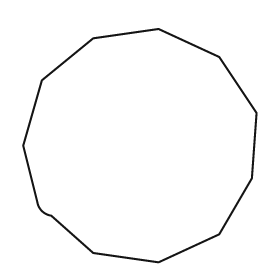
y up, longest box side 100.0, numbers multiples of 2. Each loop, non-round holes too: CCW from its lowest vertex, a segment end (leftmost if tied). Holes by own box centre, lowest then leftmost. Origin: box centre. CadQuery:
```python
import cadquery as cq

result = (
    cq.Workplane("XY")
    .moveTo(8.0, -50.0)
    .lineTo(34.0, -38.0)
    .lineTo(48.0, -14.0)
    .lineTo(50.0, 14.0)
    .lineTo(34.0, 38.0)
    .lineTo(8.0, 50.0)
    .lineTo(-20.0, 46.0)
    .lineTo(-42.0, 28.0)
    .lineTo(-50.0, 0.0)
    .lineTo(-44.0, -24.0)
    .threePointArc((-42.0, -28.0), (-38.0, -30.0))
    .lineTo(-20.0, -46.0)
    .close()
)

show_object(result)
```